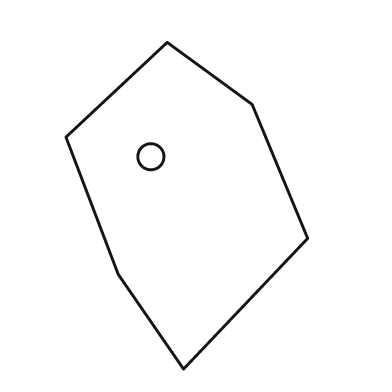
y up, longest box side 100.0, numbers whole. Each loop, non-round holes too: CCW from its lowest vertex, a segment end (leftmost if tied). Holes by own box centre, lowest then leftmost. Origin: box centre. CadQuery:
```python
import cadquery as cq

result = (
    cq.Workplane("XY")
    .moveTo(-1.0, -50.0)
    .lineTo(37.0, -10.0)
    .lineTo(20.0, 31.0)
    .lineTo(-6.0, 50.0)
    .lineTo(-37.0, 21.0)
    .lineTo(-21.0, -21.0)
    .close()
    .moveTo(-11.0, 15.0)
    .circle(4.0)
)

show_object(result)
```